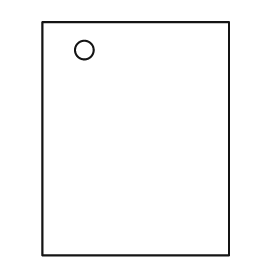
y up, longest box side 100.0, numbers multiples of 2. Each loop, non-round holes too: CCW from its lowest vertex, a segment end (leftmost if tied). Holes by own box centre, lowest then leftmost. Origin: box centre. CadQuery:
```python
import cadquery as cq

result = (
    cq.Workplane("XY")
    .moveTo(-40.0, -50.0)
    .lineTo(40.0, -50.0)
    .lineTo(40.0, 50.0)
    .lineTo(-40.0, 50.0)
    .close()
    .moveTo(-22.0, 38.0)
    .circle(4.0)
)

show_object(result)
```